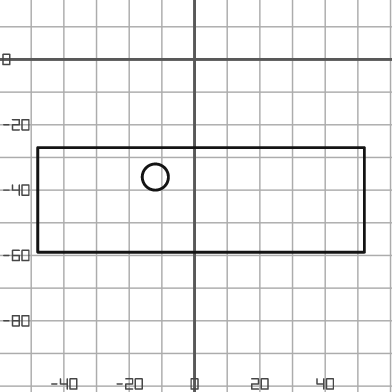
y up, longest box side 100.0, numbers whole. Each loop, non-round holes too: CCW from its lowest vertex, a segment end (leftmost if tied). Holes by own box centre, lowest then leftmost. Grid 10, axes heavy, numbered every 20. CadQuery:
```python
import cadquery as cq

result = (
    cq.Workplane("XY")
    .moveTo(-48.0, -59.0)
    .lineTo(52.0, -59.0)
    .lineTo(52.0, -27.0)
    .lineTo(-48.0, -27.0)
    .close()
    .moveTo(-12.0, -36.0)
    .circle(4.0)
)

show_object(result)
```